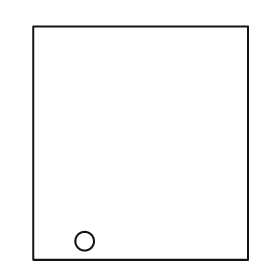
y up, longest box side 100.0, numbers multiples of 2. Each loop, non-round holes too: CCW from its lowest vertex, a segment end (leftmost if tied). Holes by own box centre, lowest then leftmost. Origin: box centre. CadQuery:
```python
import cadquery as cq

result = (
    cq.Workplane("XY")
    .moveTo(-46.0, -50.0)
    .lineTo(46.0, -50.0)
    .lineTo(46.0, 50.0)
    .lineTo(-46.0, 50.0)
    .close()
    .moveTo(-24.0, -42.0)
    .circle(4.0)
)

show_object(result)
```